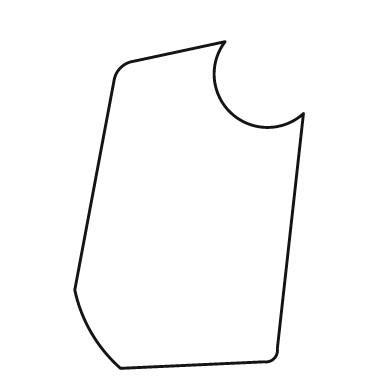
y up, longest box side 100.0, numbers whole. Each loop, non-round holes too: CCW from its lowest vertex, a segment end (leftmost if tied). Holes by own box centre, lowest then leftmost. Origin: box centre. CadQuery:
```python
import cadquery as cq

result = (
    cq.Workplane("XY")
    .moveTo(-21.0, -50.0)
    .lineTo(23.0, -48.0)
    .threePointArc((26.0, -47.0), (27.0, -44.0))
    .lineTo(35.0, 28.0)
    .threePointArc((13.0, 28.0), (11.0, 50.0))
    .lineTo(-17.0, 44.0)
    .threePointArc((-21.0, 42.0), (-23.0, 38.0))
    .lineTo(-35.0, -26.0)
    .threePointArc((-30.0, -39.0), (-21.0, -50.0))
    .close()
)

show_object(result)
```